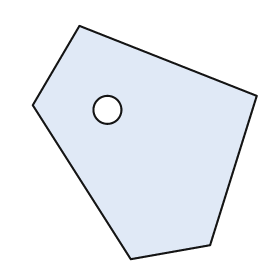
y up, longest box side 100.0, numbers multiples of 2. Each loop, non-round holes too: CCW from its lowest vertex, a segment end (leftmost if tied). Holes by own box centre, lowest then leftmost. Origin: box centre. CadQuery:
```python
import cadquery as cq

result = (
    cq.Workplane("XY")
    .moveTo(-6.0, -50.0)
    .lineTo(28.0, -44.0)
    .lineTo(48.0, 20.0)
    .lineTo(-28.0, 50.0)
    .lineTo(-48.0, 16.0)
    .close()
    .moveTo(-16.0, 14.0)
    .circle(6.0)
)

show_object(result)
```